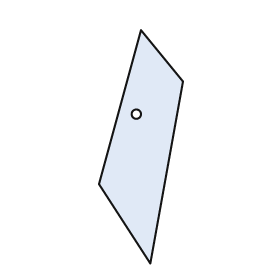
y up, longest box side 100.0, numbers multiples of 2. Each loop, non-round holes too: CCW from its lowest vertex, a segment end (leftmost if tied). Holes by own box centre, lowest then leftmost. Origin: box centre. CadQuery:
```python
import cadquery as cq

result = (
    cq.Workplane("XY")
    .moveTo(4.0, -50.0)
    .lineTo(18.0, 28.0)
    .lineTo(0.0, 50.0)
    .lineTo(-18.0, -16.0)
    .close()
    .moveTo(-2.0, 14.0)
    .circle(2.0)
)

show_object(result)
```